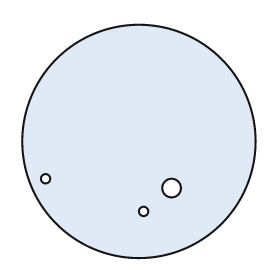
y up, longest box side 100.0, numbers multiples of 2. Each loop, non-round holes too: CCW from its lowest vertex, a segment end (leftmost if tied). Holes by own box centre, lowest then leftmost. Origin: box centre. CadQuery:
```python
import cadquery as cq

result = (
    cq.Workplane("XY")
    .moveTo(0.0, 0.0)
    .circle(50.0)
    .moveTo(2.0, -30.0)
    .circle(2.0)
    .moveTo(14.0, -20.0)
    .circle(4.0)
    .moveTo(-40.0, -16.0)
    .circle(2.0)
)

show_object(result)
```